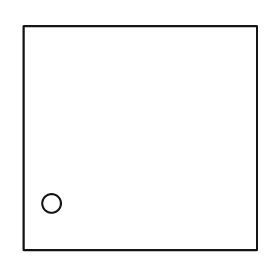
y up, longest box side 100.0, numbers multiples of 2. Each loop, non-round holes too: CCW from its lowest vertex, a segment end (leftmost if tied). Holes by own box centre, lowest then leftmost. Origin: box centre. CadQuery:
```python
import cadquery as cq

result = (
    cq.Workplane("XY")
    .moveTo(-50.0, -48.0)
    .lineTo(50.0, -48.0)
    .lineTo(50.0, 48.0)
    .lineTo(-50.0, 48.0)
    .close()
    .moveTo(-38.0, -28.0)
    .circle(4.0)
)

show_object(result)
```